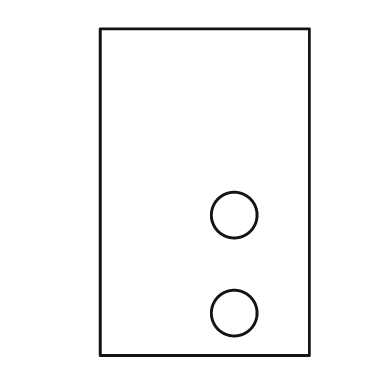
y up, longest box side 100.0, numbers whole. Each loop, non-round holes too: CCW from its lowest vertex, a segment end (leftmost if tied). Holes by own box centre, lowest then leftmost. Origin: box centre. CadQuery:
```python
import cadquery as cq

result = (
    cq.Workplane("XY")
    .moveTo(-32.0, -50.0)
    .lineTo(32.0, -50.0)
    .lineTo(32.0, 50.0)
    .lineTo(-32.0, 50.0)
    .close()
    .moveTo(9.0, -37.0)
    .circle(7.0)
    .moveTo(9.0, -7.0)
    .circle(7.0)
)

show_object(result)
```